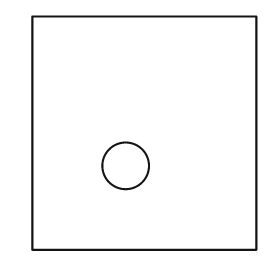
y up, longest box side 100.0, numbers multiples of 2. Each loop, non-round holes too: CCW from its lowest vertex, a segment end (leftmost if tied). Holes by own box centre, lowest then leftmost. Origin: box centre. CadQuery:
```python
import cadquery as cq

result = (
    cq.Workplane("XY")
    .moveTo(-48.0, -50.0)
    .lineTo(48.0, -50.0)
    .lineTo(48.0, 50.0)
    .lineTo(-48.0, 50.0)
    .close()
    .moveTo(-8.0, -14.0)
    .circle(10.0)
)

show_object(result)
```